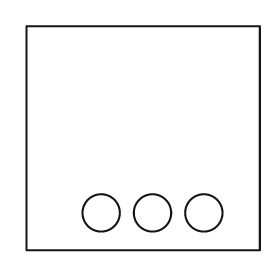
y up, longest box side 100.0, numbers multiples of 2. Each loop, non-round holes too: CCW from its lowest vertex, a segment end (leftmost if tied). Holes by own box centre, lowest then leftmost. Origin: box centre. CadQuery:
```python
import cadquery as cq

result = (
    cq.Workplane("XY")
    .moveTo(-50.0, -48.0)
    .lineTo(50.0, -48.0)
    .lineTo(50.0, 48.0)
    .lineTo(-50.0, 48.0)
    .close()
    .moveTo(-18.0, -32.0)
    .circle(8.0)
    .moveTo(4.0, -32.0)
    .circle(8.0)
    .moveTo(26.0, -32.0)
    .circle(8.0)
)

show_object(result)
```